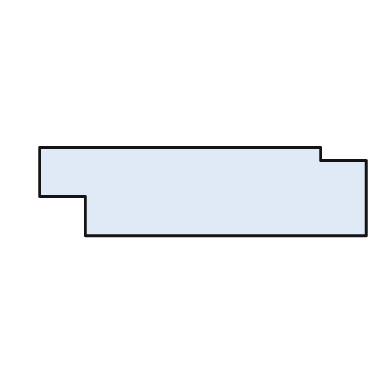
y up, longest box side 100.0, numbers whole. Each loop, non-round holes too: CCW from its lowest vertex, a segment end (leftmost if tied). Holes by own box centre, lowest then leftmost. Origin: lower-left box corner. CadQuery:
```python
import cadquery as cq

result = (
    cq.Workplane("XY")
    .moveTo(14.0, 0.0)
    .lineTo(100.0, 0.0)
    .lineTo(100.0, 23.0)
    .lineTo(86.0, 23.0)
    .lineTo(86.0, 27.0)
    .lineTo(0.0, 27.0)
    .lineTo(0.0, 12.0)
    .lineTo(14.0, 12.0)
    .close()
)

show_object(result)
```